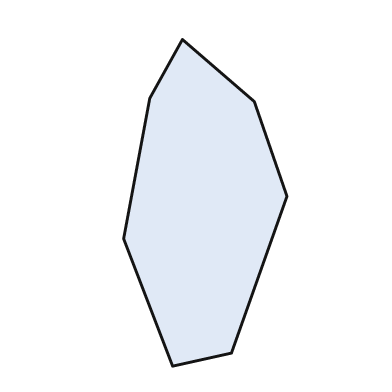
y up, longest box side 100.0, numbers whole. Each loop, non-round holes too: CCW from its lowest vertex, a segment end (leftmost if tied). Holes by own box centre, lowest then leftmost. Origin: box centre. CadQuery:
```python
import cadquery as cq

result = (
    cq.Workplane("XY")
    .moveTo(-10.0, -50.0)
    .lineTo(8.0, -46.0)
    .lineTo(25.0, 2.0)
    .lineTo(15.0, 31.0)
    .lineTo(-7.0, 50.0)
    .lineTo(-17.0, 32.0)
    .lineTo(-25.0, -11.0)
    .close()
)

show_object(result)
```